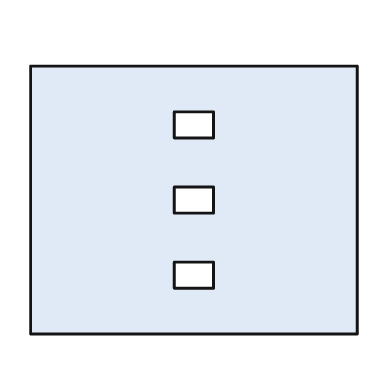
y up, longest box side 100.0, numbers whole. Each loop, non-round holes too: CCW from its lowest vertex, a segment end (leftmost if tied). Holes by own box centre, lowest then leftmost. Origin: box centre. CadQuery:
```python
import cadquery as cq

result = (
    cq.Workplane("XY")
    .moveTo(-50.0, -41.0)
    .lineTo(50.0, -41.0)
    .lineTo(50.0, 41.0)
    .lineTo(-50.0, 41.0)
    .close()
    .moveTo(-6.0, -27.0)
    .lineTo(6.0, -27.0)
    .lineTo(6.0, -19.0)
    .lineTo(-6.0, -19.0)
    .close()
    .moveTo(-6.0, -4.0)
    .lineTo(6.0, -4.0)
    .lineTo(6.0, 4.0)
    .lineTo(-6.0, 4.0)
    .close()
    .moveTo(-6.0, 19.0)
    .lineTo(6.0, 19.0)
    .lineTo(6.0, 27.0)
    .lineTo(-6.0, 27.0)
    .close()
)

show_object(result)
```